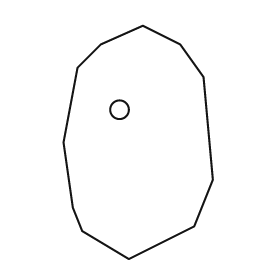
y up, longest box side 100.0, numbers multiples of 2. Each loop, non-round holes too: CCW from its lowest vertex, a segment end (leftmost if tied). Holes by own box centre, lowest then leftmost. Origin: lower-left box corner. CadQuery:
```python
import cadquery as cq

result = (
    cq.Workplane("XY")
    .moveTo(28.0, 0.0)
    .lineTo(56.0, 14.0)
    .lineTo(64.0, 34.0)
    .lineTo(60.0, 78.0)
    .lineTo(50.0, 92.0)
    .lineTo(34.0, 100.0)
    .lineTo(16.0, 92.0)
    .lineTo(6.0, 82.0)
    .lineTo(0.0, 50.0)
    .lineTo(4.0, 22.0)
    .lineTo(8.0, 12.0)
    .close()
    .moveTo(24.0, 64.0)
    .circle(4.0)
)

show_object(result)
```